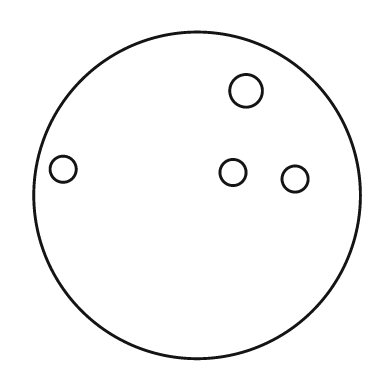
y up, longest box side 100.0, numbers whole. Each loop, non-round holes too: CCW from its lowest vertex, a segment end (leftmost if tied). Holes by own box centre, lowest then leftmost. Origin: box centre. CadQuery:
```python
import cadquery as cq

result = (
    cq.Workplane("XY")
    .moveTo(0.0, 0.0)
    .circle(50.0)
    .moveTo(30.0, 5.0)
    .circle(4.0)
    .moveTo(11.0, 7.0)
    .circle(4.0)
    .moveTo(-41.0, 8.0)
    .circle(4.0)
    .moveTo(15.0, 32.0)
    .circle(5.0)
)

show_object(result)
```